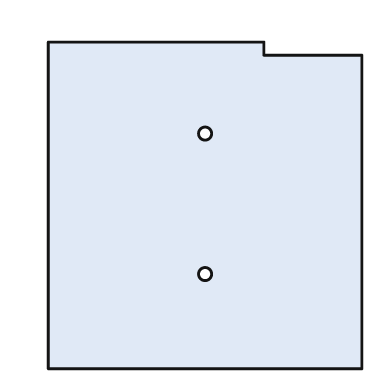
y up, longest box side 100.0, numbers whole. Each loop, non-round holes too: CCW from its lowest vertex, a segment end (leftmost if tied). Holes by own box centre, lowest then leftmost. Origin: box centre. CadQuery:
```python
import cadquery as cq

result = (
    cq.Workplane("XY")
    .moveTo(-48.0, -50.0)
    .lineTo(48.0, -50.0)
    .lineTo(48.0, 46.0)
    .lineTo(18.0, 46.0)
    .lineTo(18.0, 50.0)
    .lineTo(-48.0, 50.0)
    .close()
    .moveTo(0.0, -21.0)
    .circle(2.0)
    .moveTo(0.0, 22.0)
    .circle(2.0)
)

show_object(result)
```